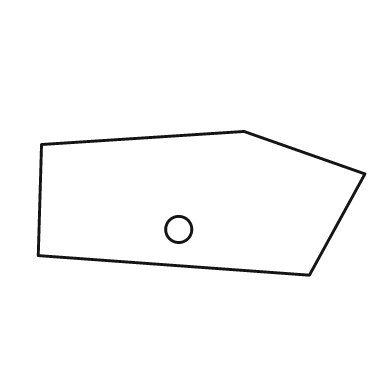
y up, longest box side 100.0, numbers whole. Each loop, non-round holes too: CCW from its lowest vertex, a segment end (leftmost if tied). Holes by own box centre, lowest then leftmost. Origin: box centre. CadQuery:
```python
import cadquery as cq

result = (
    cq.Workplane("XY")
    .moveTo(33.0, -22.0)
    .lineTo(50.0, 9.0)
    .lineTo(13.0, 22.0)
    .lineTo(-49.0, 18.0)
    .lineTo(-50.0, -16.0)
    .close()
    .moveTo(-7.0, -8.0)
    .circle(4.0)
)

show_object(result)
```